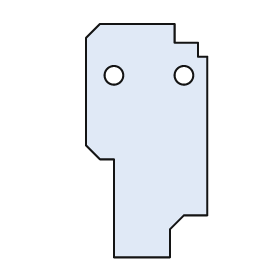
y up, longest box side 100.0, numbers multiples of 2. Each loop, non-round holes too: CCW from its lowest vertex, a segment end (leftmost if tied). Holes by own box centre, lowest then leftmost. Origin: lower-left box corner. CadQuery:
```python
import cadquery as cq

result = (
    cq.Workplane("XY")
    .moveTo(12.0, 0.0)
    .lineTo(36.0, 0.0)
    .lineTo(36.0, 12.0)
    .lineTo(42.0, 18.0)
    .lineTo(52.0, 18.0)
    .lineTo(52.0, 86.0)
    .lineTo(48.0, 86.0)
    .lineTo(48.0, 92.0)
    .lineTo(38.0, 92.0)
    .lineTo(38.0, 100.0)
    .lineTo(6.0, 100.0)
    .lineTo(0.0, 94.0)
    .lineTo(0.0, 48.0)
    .lineTo(6.0, 42.0)
    .lineTo(12.0, 42.0)
    .close()
    .moveTo(12.0, 78.0)
    .circle(4.0)
    .moveTo(42.0, 78.0)
    .circle(4.0)
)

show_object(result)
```